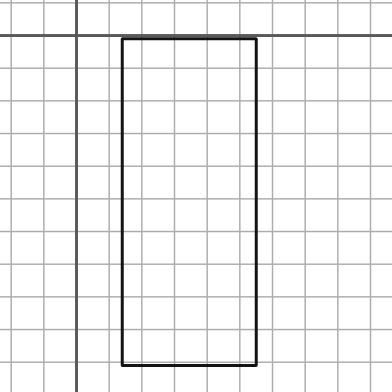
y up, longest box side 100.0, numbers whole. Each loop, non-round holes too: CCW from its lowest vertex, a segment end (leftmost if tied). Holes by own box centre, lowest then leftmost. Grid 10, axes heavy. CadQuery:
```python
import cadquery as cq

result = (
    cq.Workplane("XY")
    .moveTo(14.0, -101.0)
    .lineTo(55.0, -101.0)
    .lineTo(55.0, -1.0)
    .lineTo(14.0, -1.0)
    .close()
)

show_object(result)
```